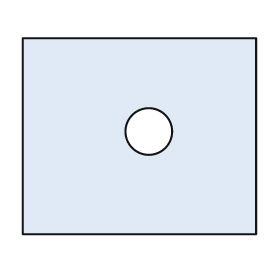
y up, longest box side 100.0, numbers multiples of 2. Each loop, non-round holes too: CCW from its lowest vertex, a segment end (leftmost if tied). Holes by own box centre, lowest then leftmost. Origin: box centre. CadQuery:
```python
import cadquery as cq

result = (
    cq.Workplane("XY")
    .moveTo(-50.0, -42.0)
    .lineTo(50.0, -42.0)
    .lineTo(50.0, 42.0)
    .lineTo(-50.0, 42.0)
    .close()
    .moveTo(4.0, 2.0)
    .circle(10.0)
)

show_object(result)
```